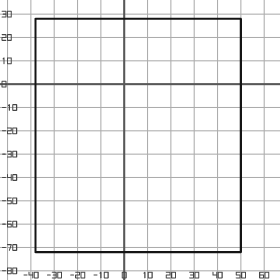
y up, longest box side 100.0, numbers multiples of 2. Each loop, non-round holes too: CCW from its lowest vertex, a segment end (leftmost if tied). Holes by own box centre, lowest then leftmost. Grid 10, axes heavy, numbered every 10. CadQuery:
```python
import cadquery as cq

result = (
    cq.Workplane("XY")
    .moveTo(-38.0, -72.0)
    .lineTo(50.0, -72.0)
    .lineTo(50.0, 28.0)
    .lineTo(-38.0, 28.0)
    .close()
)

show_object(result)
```